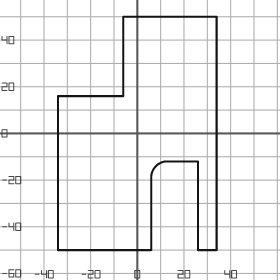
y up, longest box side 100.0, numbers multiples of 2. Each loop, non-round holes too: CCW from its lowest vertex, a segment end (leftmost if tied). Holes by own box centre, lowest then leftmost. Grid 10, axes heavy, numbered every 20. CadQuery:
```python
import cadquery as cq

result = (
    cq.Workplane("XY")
    .moveTo(-34.0, -50.0)
    .lineTo(6.0, -50.0)
    .lineTo(6.0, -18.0)
    .threePointArc((8.0, -14.0), (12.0, -12.0))
    .lineTo(26.0, -12.0)
    .lineTo(26.0, -50.0)
    .lineTo(34.0, -50.0)
    .lineTo(34.0, 50.0)
    .lineTo(-6.0, 50.0)
    .lineTo(-6.0, 16.0)
    .lineTo(-34.0, 16.0)
    .close()
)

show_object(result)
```